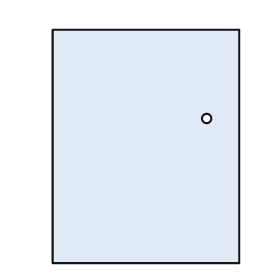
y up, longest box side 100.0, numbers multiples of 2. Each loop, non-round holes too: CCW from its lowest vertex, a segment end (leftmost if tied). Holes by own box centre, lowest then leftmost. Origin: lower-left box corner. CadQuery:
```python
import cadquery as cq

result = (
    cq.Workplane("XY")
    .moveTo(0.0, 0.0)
    .lineTo(80.0, 0.0)
    .lineTo(80.0, 100.0)
    .lineTo(0.0, 100.0)
    .close()
    .moveTo(66.0, 62.0)
    .circle(2.0)
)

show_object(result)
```